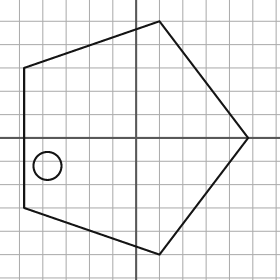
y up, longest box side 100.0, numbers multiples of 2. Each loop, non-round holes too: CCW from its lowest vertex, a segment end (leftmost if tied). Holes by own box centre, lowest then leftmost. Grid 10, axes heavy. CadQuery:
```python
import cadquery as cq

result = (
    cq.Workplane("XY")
    .moveTo(10.0, -50.0)
    .lineTo(48.0, 0.0)
    .lineTo(10.0, 50.0)
    .lineTo(-48.0, 30.0)
    .lineTo(-48.0, -30.0)
    .close()
    .moveTo(-38.0, -12.0)
    .circle(6.0)
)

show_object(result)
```